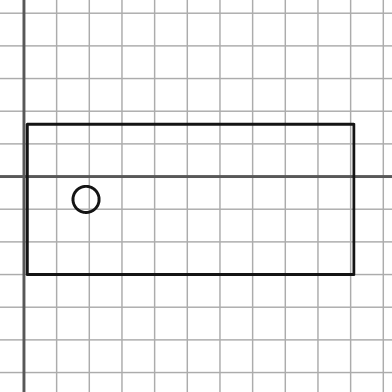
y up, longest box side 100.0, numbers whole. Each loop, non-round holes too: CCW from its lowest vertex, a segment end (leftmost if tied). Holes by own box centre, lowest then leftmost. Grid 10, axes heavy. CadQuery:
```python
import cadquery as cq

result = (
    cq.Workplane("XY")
    .moveTo(1.0, -30.0)
    .lineTo(101.0, -30.0)
    .lineTo(101.0, 16.0)
    .lineTo(1.0, 16.0)
    .close()
    .moveTo(19.0, -7.0)
    .circle(4.0)
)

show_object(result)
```